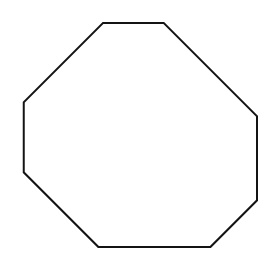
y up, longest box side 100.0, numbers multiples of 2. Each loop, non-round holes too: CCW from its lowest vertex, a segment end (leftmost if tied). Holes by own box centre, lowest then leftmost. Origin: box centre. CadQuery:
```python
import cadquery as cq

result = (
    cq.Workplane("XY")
    .moveTo(-18.0, -48.0)
    .lineTo(30.0, -48.0)
    .lineTo(50.0, -28.0)
    .lineTo(50.0, 8.0)
    .lineTo(10.0, 48.0)
    .lineTo(-16.0, 48.0)
    .lineTo(-50.0, 14.0)
    .lineTo(-50.0, -16.0)
    .close()
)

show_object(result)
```